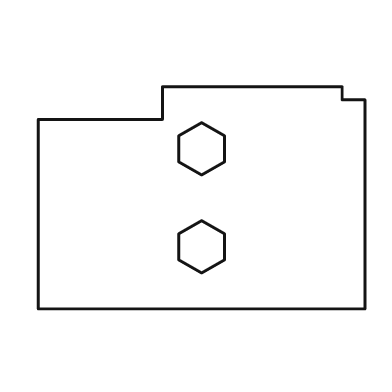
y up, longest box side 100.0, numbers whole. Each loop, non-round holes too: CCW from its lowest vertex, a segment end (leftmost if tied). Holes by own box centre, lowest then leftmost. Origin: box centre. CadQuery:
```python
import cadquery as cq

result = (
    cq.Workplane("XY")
    .moveTo(-50.0, -34.0)
    .lineTo(50.0, -34.0)
    .lineTo(50.0, 30.0)
    .lineTo(43.0, 30.0)
    .lineTo(43.0, 34.0)
    .lineTo(-12.0, 34.0)
    .lineTo(-12.0, 24.0)
    .lineTo(-50.0, 24.0)
    .close()
    .moveTo(0.0, -23.0)
    .lineTo(7.0, -19.0)
    .lineTo(7.0, -11.0)
    .lineTo(0.0, -7.0)
    .lineTo(-7.0, -11.0)
    .lineTo(-7.0, -19.0)
    .close()
    .moveTo(0.0, 7.0)
    .lineTo(7.0, 11.0)
    .lineTo(7.0, 19.0)
    .lineTo(0.0, 23.0)
    .lineTo(-7.0, 19.0)
    .lineTo(-7.0, 11.0)
    .close()
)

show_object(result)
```